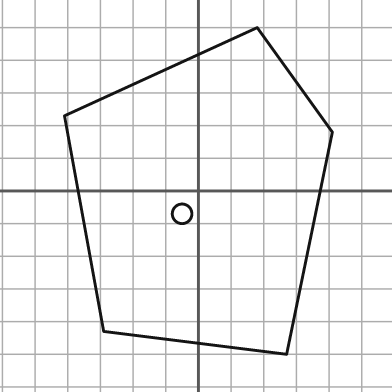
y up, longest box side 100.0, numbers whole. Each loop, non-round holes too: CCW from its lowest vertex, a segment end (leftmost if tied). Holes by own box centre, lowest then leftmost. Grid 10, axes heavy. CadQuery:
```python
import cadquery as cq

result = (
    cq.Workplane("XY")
    .moveTo(27.0, -50.0)
    .lineTo(41.0, 18.0)
    .lineTo(18.0, 50.0)
    .lineTo(-41.0, 23.0)
    .lineTo(-29.0, -43.0)
    .close()
    .moveTo(-5.0, -7.0)
    .circle(3.0)
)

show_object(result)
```